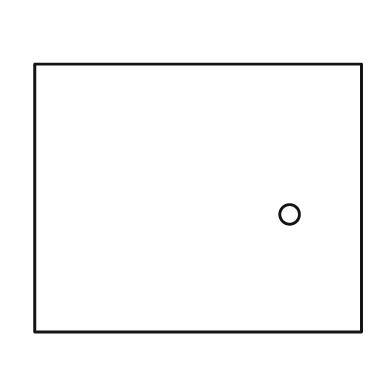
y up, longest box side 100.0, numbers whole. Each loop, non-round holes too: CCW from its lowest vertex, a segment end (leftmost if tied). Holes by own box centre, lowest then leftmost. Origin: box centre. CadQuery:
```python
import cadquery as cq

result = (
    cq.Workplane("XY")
    .moveTo(-50.0, -41.0)
    .lineTo(50.0, -41.0)
    .lineTo(50.0, 41.0)
    .lineTo(-50.0, 41.0)
    .close()
    .moveTo(28.0, -5.0)
    .circle(3.0)
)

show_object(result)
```